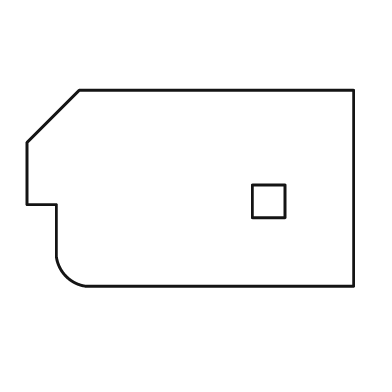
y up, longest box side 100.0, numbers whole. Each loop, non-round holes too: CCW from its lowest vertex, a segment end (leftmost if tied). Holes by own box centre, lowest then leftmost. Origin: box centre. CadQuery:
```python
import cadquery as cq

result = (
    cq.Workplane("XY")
    .moveTo(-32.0, -30.0)
    .lineTo(50.0, -30.0)
    .lineTo(50.0, 30.0)
    .lineTo(-34.0, 30.0)
    .lineTo(-50.0, 14.0)
    .lineTo(-50.0, -5.0)
    .lineTo(-41.0, -5.0)
    .lineTo(-41.0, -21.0)
    .threePointArc((-38.0, -27.0), (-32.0, -30.0))
    .close()
    .moveTo(19.0, -9.0)
    .lineTo(29.0, -9.0)
    .lineTo(29.0, 1.0)
    .lineTo(19.0, 1.0)
    .close()
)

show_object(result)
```